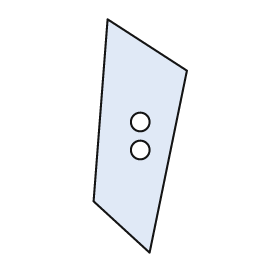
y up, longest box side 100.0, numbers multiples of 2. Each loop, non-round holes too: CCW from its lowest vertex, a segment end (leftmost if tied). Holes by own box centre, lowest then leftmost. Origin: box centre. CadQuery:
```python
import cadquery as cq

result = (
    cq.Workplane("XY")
    .moveTo(4.0, -50.0)
    .lineTo(20.0, 28.0)
    .lineTo(-14.0, 50.0)
    .lineTo(-20.0, -28.0)
    .close()
    .moveTo(0.0, -6.0)
    .circle(4.0)
    .moveTo(0.0, 6.0)
    .circle(4.0)
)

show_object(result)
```